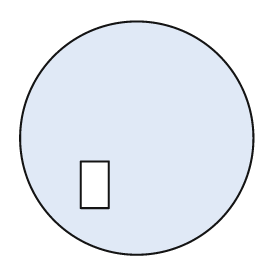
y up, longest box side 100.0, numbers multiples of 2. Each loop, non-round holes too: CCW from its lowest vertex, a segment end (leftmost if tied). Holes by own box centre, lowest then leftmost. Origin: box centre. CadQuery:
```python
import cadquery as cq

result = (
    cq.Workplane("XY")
    .moveTo(0.0, 0.0)
    .circle(50.0)
    .moveTo(-24.0, -30.0)
    .lineTo(-12.0, -30.0)
    .lineTo(-12.0, -10.0)
    .lineTo(-24.0, -10.0)
    .close()
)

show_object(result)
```